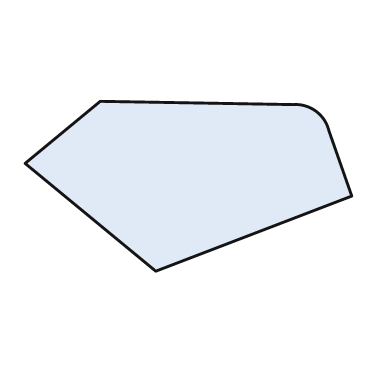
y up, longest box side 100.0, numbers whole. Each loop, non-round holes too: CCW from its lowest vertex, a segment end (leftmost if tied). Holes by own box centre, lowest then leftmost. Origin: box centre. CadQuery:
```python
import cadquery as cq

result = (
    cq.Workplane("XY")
    .moveTo(-10.0, -26.0)
    .lineTo(50.0, -3.0)
    .lineTo(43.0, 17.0)
    .threePointArc((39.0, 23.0), (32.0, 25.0))
    .lineTo(-27.0, 26.0)
    .lineTo(-50.0, 7.0)
    .close()
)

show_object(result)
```